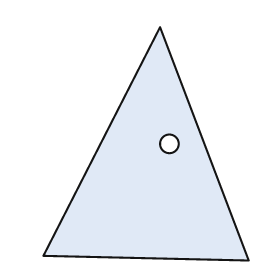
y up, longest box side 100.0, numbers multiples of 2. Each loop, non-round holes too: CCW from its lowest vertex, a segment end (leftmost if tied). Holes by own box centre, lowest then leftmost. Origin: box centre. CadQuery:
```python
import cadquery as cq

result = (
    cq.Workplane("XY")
    .moveTo(44.0, -50.0)
    .lineTo(6.0, 50.0)
    .lineTo(-44.0, -48.0)
    .close()
    .moveTo(10.0, 0.0)
    .circle(4.0)
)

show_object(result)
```